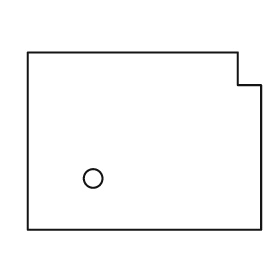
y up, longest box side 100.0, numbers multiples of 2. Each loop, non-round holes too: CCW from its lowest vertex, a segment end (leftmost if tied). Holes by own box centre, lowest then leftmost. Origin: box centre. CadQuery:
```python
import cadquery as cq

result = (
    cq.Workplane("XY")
    .moveTo(-50.0, -38.0)
    .lineTo(50.0, -38.0)
    .lineTo(50.0, 24.0)
    .lineTo(40.0, 24.0)
    .lineTo(40.0, 38.0)
    .lineTo(-50.0, 38.0)
    .close()
    .moveTo(-22.0, -16.0)
    .circle(4.0)
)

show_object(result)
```